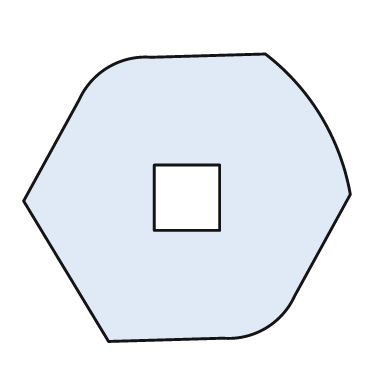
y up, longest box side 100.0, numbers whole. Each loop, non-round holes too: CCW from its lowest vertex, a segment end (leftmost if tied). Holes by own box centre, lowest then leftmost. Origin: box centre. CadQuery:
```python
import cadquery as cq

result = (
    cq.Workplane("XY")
    .moveTo(-24.0, -44.0)
    .lineTo(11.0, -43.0)
    .threePointArc((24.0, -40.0), (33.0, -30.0))
    .lineTo(50.0, 1.0)
    .threePointArc((41.0, 25.0), (24.0, 44.0))
    .lineTo(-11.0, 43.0)
    .threePointArc((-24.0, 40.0), (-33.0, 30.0))
    .lineTo(-50.0, -1.0)
    .close()
    .moveTo(-10.0, -10.0)
    .lineTo(10.0, -10.0)
    .lineTo(10.0, 10.0)
    .lineTo(-10.0, 10.0)
    .close()
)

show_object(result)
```